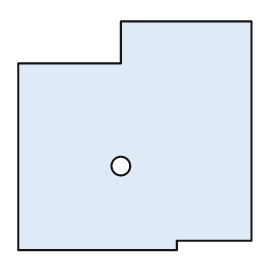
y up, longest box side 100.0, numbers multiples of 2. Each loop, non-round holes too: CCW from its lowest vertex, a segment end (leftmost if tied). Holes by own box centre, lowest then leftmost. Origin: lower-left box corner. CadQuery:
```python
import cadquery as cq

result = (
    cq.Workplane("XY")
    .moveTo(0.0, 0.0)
    .lineTo(68.0, 0.0)
    .lineTo(68.0, 4.0)
    .lineTo(100.0, 4.0)
    .lineTo(100.0, 98.0)
    .lineTo(44.0, 98.0)
    .lineTo(44.0, 80.0)
    .lineTo(0.0, 80.0)
    .close()
    .moveTo(44.0, 36.0)
    .circle(4.0)
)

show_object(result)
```